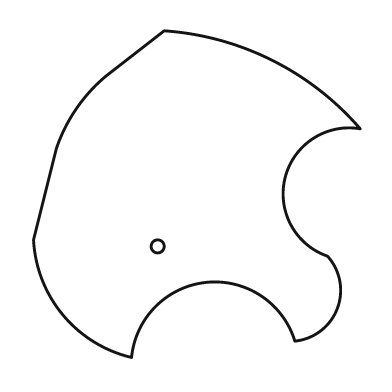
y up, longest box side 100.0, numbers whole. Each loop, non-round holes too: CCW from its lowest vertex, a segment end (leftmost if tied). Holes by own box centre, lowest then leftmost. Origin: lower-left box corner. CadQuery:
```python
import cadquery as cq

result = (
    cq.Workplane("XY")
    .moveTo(30.0, 0.0)
    .threePointArc((53.0, 23.0), (80.0, 5.0))
    .threePointArc((93.0, 15.0), (90.0, 31.0))
    .threePointArc((77.0, 55.0), (100.0, 70.0))
    .threePointArc((73.0, 91.0), (40.0, 100.0))
    .lineTo(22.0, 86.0)
    .threePointArc((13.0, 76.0), (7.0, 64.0))
    .lineTo(0.0, 36.0)
    .threePointArc((9.0, 13.0), (30.0, 0.0))
    .close()
    .moveTo(38.0, 34.0)
    .circle(2.0)
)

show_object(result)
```